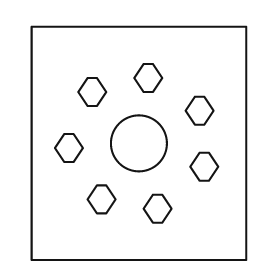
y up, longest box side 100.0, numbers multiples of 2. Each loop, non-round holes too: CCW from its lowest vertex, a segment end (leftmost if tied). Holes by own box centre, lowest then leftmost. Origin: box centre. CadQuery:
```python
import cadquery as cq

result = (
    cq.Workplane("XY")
    .moveTo(-46.0, -50.0)
    .lineTo(46.0, -50.0)
    .lineTo(46.0, 50.0)
    .lineTo(-46.0, 50.0)
    .close()
    .moveTo(6.0, -34.0)
    .lineTo(10.0, -34.0)
    .lineTo(14.0, -28.0)
    .lineTo(10.0, -22.0)
    .lineTo(6.0, -22.0)
    .lineTo(2.0, -28.0)
    .close()
    .moveTo(-18.0, -30.0)
    .lineTo(-14.0, -30.0)
    .lineTo(-10.0, -24.0)
    .lineTo(-14.0, -18.0)
    .lineTo(-18.0, -18.0)
    .lineTo(-22.0, -24.0)
    .close()
    .moveTo(26.0, -16.0)
    .lineTo(30.0, -16.0)
    .lineTo(34.0, -10.0)
    .lineTo(30.0, -4.0)
    .lineTo(26.0, -4.0)
    .lineTo(22.0, -10.0)
    .close()
    .moveTo(-32.0, -8.0)
    .lineTo(-28.0, -8.0)
    .lineTo(-24.0, -2.0)
    .lineTo(-28.0, 4.0)
    .lineTo(-32.0, 4.0)
    .lineTo(-36.0, -2.0)
    .close()
    .moveTo(0.0, 0.0)
    .circle(12.0)
    .moveTo(24.0, 8.0)
    .lineTo(28.0, 8.0)
    .lineTo(32.0, 14.0)
    .lineTo(28.0, 20.0)
    .lineTo(24.0, 20.0)
    .lineTo(20.0, 14.0)
    .close()
    .moveTo(-22.0, 16.0)
    .lineTo(-18.0, 16.0)
    .lineTo(-14.0, 22.0)
    .lineTo(-18.0, 28.0)
    .lineTo(-22.0, 28.0)
    .lineTo(-26.0, 22.0)
    .close()
    .moveTo(2.0, 22.0)
    .lineTo(6.0, 22.0)
    .lineTo(10.0, 28.0)
    .lineTo(6.0, 34.0)
    .lineTo(2.0, 34.0)
    .lineTo(-2.0, 28.0)
    .close()
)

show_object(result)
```